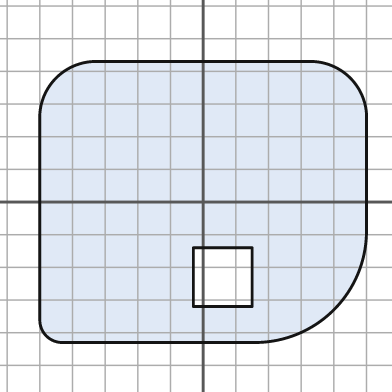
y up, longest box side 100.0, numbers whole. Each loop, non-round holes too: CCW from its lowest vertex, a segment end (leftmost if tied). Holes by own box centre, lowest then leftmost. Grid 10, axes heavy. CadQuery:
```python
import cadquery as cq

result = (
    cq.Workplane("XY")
    .moveTo(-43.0, -43.0)
    .lineTo(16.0, -43.0)
    .threePointArc((40.0, -33.0), (50.0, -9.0))
    .lineTo(50.0, 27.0)
    .threePointArc((45.0, 38.0), (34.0, 43.0))
    .lineTo(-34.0, 43.0)
    .threePointArc((-45.0, 38.0), (-50.0, 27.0))
    .lineTo(-50.0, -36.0)
    .threePointArc((-48.0, -41.0), (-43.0, -43.0))
    .close()
    .moveTo(-3.0, -32.0)
    .lineTo(15.0, -32.0)
    .lineTo(15.0, -14.0)
    .lineTo(-3.0, -14.0)
    .close()
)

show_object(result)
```